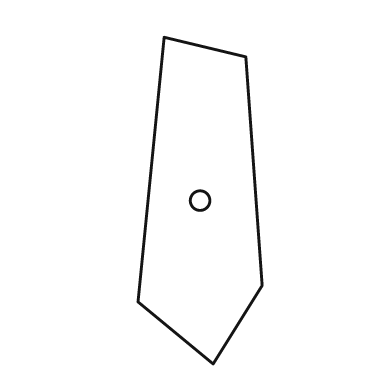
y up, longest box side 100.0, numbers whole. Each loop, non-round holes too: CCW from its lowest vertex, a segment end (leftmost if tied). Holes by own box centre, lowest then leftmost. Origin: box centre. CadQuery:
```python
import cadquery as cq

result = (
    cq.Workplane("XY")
    .moveTo(4.0, -50.0)
    .lineTo(19.0, -26.0)
    .lineTo(14.0, 44.0)
    .lineTo(-11.0, 50.0)
    .lineTo(-19.0, -31.0)
    .close()
    .moveTo(0.0, 0.0)
    .circle(3.0)
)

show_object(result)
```